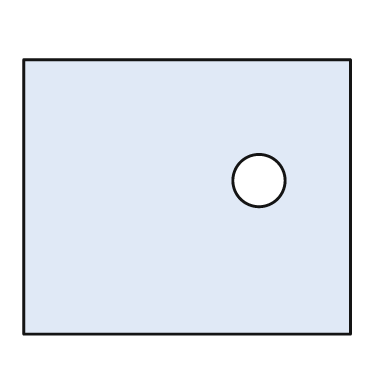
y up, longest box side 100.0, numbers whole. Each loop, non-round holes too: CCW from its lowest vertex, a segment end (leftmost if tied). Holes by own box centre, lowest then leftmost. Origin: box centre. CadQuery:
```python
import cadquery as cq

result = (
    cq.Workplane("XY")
    .moveTo(-50.0, -42.0)
    .lineTo(50.0, -42.0)
    .lineTo(50.0, 42.0)
    .lineTo(-50.0, 42.0)
    .close()
    .moveTo(22.0, 5.0)
    .circle(8.0)
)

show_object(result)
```